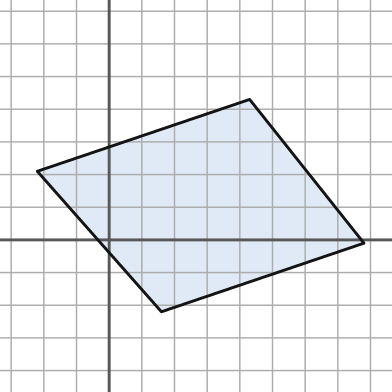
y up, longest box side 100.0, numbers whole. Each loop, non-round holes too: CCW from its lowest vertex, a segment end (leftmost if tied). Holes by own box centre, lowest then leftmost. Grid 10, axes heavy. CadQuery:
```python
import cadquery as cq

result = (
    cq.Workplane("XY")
    .moveTo(16.0, -22.0)
    .lineTo(78.0, -1.0)
    .lineTo(43.0, 43.0)
    .lineTo(-22.0, 21.0)
    .close()
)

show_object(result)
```